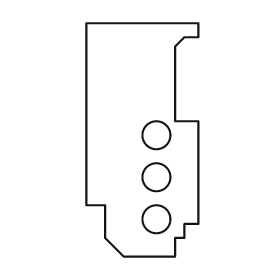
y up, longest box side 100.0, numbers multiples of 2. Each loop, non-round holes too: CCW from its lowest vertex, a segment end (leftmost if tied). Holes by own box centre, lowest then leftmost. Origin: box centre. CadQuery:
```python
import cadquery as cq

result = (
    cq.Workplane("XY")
    .moveTo(-8.0, -50.0)
    .lineTo(14.0, -50.0)
    .lineTo(14.0, -42.0)
    .lineTo(18.0, -42.0)
    .lineTo(18.0, -36.0)
    .lineTo(24.0, -36.0)
    .lineTo(24.0, 8.0)
    .lineTo(14.0, 8.0)
    .lineTo(14.0, 40.0)
    .lineTo(18.0, 44.0)
    .lineTo(24.0, 44.0)
    .lineTo(24.0, 50.0)
    .lineTo(-24.0, 50.0)
    .lineTo(-24.0, -28.0)
    .lineTo(-16.0, -28.0)
    .lineTo(-16.0, -42.0)
    .close()
    .moveTo(6.0, -34.0)
    .circle(6.0)
    .moveTo(6.0, -16.0)
    .circle(6.0)
    .moveTo(6.0, 2.0)
    .circle(6.0)
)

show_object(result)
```